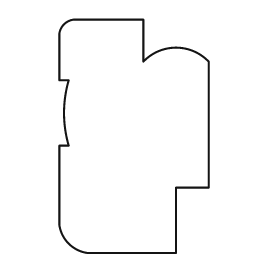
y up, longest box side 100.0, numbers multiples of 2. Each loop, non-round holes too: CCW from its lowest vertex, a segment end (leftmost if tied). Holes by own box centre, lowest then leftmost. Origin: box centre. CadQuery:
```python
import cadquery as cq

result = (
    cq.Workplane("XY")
    .moveTo(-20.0, -50.0)
    .lineTo(18.0, -50.0)
    .lineTo(18.0, -22.0)
    .lineTo(32.0, -22.0)
    .lineTo(32.0, 32.0)
    .threePointArc((18.0, 38.0), (4.0, 32.0))
    .lineTo(4.0, 50.0)
    .lineTo(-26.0, 50.0)
    .threePointArc((-30.0, 48.0), (-32.0, 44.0))
    .lineTo(-32.0, 24.0)
    .lineTo(-28.0, 24.0)
    .threePointArc((-30.0, 10.0), (-28.0, -4.0))
    .lineTo(-32.0, -4.0)
    .lineTo(-32.0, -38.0)
    .threePointArc((-28.0, -46.0), (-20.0, -50.0))
    .close()
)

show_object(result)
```